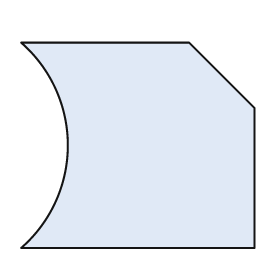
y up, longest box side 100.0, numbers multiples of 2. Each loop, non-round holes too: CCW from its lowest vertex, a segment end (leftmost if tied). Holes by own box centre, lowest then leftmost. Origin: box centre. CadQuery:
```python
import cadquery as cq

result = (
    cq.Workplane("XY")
    .moveTo(-50.0, -44.0)
    .lineTo(50.0, -44.0)
    .lineTo(50.0, 16.0)
    .lineTo(22.0, 44.0)
    .lineTo(-50.0, 44.0)
    .threePointArc((-30.0, 0.0), (-50.0, -44.0))
    .close()
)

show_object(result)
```